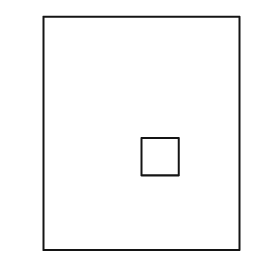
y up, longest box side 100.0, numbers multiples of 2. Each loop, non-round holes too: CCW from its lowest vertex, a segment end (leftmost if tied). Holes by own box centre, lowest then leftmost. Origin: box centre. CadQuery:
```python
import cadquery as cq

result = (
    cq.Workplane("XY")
    .moveTo(-42.0, -50.0)
    .lineTo(42.0, -50.0)
    .lineTo(42.0, 50.0)
    .lineTo(-42.0, 50.0)
    .close()
    .moveTo(0.0, -18.0)
    .lineTo(16.0, -18.0)
    .lineTo(16.0, -2.0)
    .lineTo(0.0, -2.0)
    .close()
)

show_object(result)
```